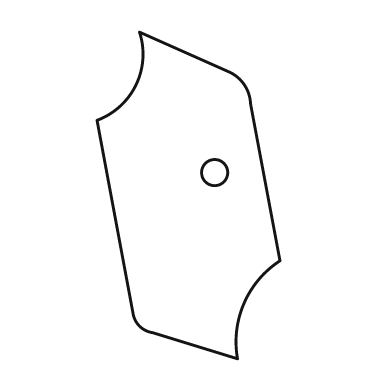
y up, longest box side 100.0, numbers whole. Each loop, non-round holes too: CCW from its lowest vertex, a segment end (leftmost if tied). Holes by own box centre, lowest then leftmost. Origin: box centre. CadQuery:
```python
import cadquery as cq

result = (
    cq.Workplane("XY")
    .moveTo(15.0, -50.0)
    .threePointArc((17.0, -33.0), (28.0, -20.0))
    .lineTo(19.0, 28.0)
    .threePointArc((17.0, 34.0), (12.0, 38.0))
    .lineTo(-15.0, 50.0)
    .threePointArc((-16.0, 34.0), (-28.0, 23.0))
    .lineTo(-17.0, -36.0)
    .threePointArc((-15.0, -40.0), (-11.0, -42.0))
    .close()
    .moveTo(8.0, 7.0)
    .circle(4.0)
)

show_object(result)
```